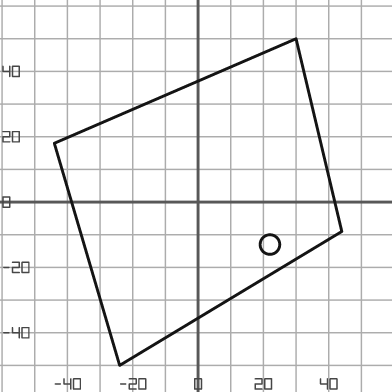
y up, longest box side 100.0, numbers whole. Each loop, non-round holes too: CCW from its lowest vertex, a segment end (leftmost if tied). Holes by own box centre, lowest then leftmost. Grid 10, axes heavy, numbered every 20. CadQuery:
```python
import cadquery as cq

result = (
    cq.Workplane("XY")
    .moveTo(-24.0, -50.0)
    .lineTo(44.0, -9.0)
    .lineTo(30.0, 50.0)
    .lineTo(-44.0, 18.0)
    .close()
    .moveTo(22.0, -13.0)
    .circle(3.0)
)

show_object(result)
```